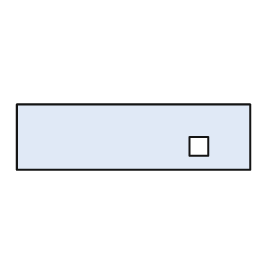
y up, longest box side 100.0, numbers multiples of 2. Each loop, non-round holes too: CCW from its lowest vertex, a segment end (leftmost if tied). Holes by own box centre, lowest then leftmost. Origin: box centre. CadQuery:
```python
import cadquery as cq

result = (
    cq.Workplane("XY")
    .moveTo(-50.0, -14.0)
    .lineTo(50.0, -14.0)
    .lineTo(50.0, 14.0)
    .lineTo(-50.0, 14.0)
    .close()
    .moveTo(24.0, -8.0)
    .lineTo(32.0, -8.0)
    .lineTo(32.0, 0.0)
    .lineTo(24.0, 0.0)
    .close()
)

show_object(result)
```